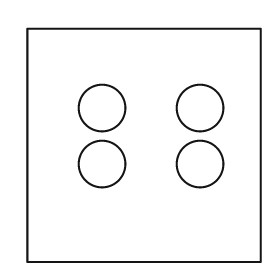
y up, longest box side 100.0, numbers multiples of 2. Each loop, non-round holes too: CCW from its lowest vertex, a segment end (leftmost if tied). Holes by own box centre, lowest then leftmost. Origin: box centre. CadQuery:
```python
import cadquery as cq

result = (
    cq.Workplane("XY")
    .moveTo(-50.0, -50.0)
    .lineTo(50.0, -50.0)
    .lineTo(50.0, 50.0)
    .lineTo(-50.0, 50.0)
    .close()
    .moveTo(-18.0, -8.0)
    .circle(10.0)
    .moveTo(24.0, -8.0)
    .circle(10.0)
    .moveTo(-18.0, 16.0)
    .circle(10.0)
    .moveTo(24.0, 16.0)
    .circle(10.0)
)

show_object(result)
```